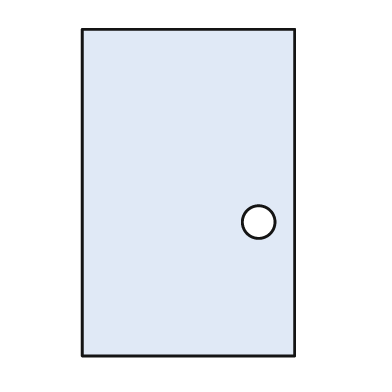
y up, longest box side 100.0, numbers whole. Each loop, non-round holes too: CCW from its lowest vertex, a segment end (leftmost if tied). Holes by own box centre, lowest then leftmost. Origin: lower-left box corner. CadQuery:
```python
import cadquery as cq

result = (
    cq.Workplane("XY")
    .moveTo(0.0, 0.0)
    .lineTo(65.0, 0.0)
    .lineTo(65.0, 100.0)
    .lineTo(0.0, 100.0)
    .close()
    .moveTo(54.0, 41.0)
    .circle(5.0)
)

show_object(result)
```